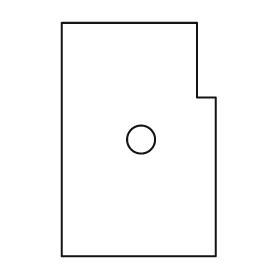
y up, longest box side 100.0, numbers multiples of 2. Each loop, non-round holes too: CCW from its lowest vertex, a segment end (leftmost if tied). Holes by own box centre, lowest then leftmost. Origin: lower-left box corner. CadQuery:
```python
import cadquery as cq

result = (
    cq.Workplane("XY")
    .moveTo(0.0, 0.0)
    .lineTo(66.0, 0.0)
    .lineTo(66.0, 68.0)
    .lineTo(58.0, 68.0)
    .lineTo(58.0, 100.0)
    .lineTo(0.0, 100.0)
    .close()
    .moveTo(34.0, 50.0)
    .circle(6.0)
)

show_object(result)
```